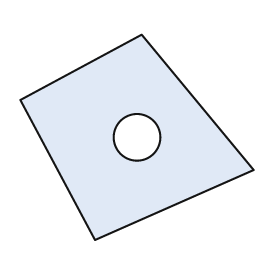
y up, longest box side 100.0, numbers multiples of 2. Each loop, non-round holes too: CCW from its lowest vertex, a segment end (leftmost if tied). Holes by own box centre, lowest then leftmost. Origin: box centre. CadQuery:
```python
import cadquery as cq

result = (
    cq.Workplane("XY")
    .moveTo(-18.0, -44.0)
    .lineTo(50.0, -14.0)
    .lineTo(2.0, 44.0)
    .lineTo(-50.0, 16.0)
    .close()
    .moveTo(0.0, 0.0)
    .circle(10.0)
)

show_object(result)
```